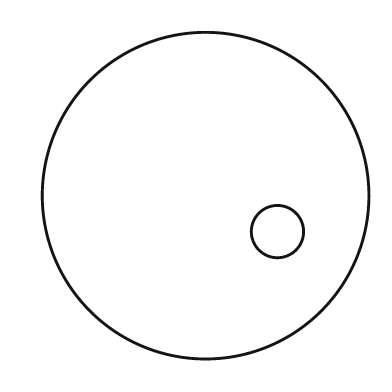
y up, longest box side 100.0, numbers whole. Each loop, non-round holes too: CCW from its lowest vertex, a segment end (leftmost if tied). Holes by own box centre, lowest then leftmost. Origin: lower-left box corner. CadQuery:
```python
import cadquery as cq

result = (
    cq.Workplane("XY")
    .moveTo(50.0, 50.0)
    .circle(50.0)
    .moveTo(72.0, 39.0)
    .circle(8.0)
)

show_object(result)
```